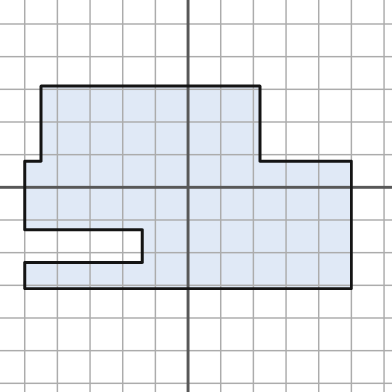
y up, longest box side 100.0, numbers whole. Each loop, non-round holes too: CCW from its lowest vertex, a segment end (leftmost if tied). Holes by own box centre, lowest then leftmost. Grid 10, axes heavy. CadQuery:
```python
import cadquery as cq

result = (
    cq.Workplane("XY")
    .moveTo(-50.0, -31.0)
    .lineTo(50.0, -31.0)
    .lineTo(50.0, 8.0)
    .lineTo(22.0, 8.0)
    .lineTo(22.0, 31.0)
    .lineTo(-45.0, 31.0)
    .lineTo(-45.0, 8.0)
    .lineTo(-50.0, 8.0)
    .lineTo(-50.0, -13.0)
    .lineTo(-14.0, -13.0)
    .lineTo(-14.0, -23.0)
    .lineTo(-50.0, -23.0)
    .close()
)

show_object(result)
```